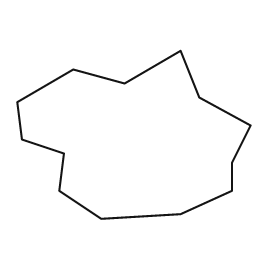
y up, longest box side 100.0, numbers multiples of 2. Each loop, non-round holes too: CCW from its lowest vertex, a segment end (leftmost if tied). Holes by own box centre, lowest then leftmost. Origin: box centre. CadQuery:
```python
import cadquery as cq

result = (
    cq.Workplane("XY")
    .moveTo(-14.0, -36.0)
    .lineTo(20.0, -34.0)
    .lineTo(42.0, -24.0)
    .lineTo(42.0, -12.0)
    .lineTo(50.0, 4.0)
    .lineTo(28.0, 16.0)
    .lineTo(20.0, 36.0)
    .lineTo(-4.0, 22.0)
    .lineTo(-26.0, 28.0)
    .lineTo(-50.0, 14.0)
    .lineTo(-48.0, -2.0)
    .lineTo(-30.0, -8.0)
    .lineTo(-32.0, -24.0)
    .close()
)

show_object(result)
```